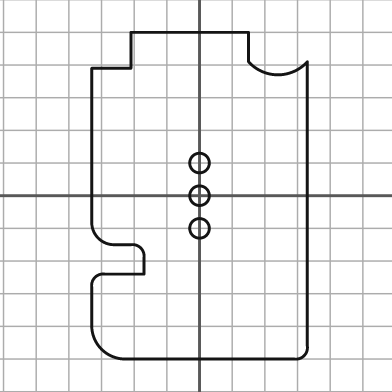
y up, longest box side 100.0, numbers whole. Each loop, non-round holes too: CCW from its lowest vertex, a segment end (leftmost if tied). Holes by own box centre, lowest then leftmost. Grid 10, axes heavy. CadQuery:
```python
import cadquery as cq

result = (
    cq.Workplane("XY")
    .moveTo(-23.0, -50.0)
    .lineTo(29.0, -50.0)
    .threePointArc((32.0, -49.0), (33.0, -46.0))
    .lineTo(33.0, 41.0)
    .threePointArc((24.0, 37.0), (15.0, 41.0))
    .lineTo(15.0, 50.0)
    .lineTo(-21.0, 50.0)
    .lineTo(-21.0, 39.0)
    .lineTo(-33.0, 39.0)
    .lineTo(-33.0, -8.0)
    .threePointArc((-31.0, -13.0), (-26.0, -15.0))
    .lineTo(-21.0, -15.0)
    .threePointArc((-18.0, -16.0), (-17.0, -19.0))
    .lineTo(-17.0, -24.0)
    .lineTo(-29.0, -24.0)
    .threePointArc((-32.0, -25.0), (-33.0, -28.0))
    .lineTo(-33.0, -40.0)
    .threePointArc((-30.0, -47.0), (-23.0, -50.0))
    .close()
    .moveTo(0.0, -10.0)
    .circle(3.0)
    .moveTo(0.0, 0.0)
    .circle(3.0)
    .moveTo(0.0, 10.0)
    .circle(3.0)
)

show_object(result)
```